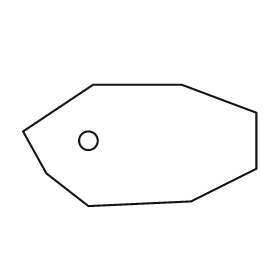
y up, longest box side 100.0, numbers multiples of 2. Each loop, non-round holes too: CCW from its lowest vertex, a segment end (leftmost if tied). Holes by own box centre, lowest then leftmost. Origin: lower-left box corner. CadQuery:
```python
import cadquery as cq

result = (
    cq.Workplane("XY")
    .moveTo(28.0, 0.0)
    .lineTo(72.0, 2.0)
    .lineTo(100.0, 16.0)
    .lineTo(100.0, 40.0)
    .lineTo(68.0, 52.0)
    .lineTo(30.0, 52.0)
    .lineTo(0.0, 32.0)
    .lineTo(10.0, 14.0)
    .close()
    .moveTo(28.0, 28.0)
    .circle(4.0)
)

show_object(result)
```